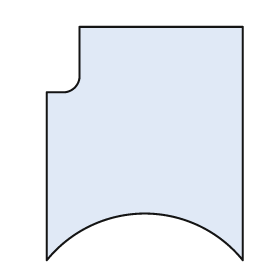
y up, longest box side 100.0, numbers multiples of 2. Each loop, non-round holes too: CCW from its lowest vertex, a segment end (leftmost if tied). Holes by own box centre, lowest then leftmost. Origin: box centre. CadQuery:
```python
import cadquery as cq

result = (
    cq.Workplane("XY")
    .moveTo(-42.0, -50.0)
    .threePointArc((0.0, -30.0), (42.0, -50.0))
    .lineTo(42.0, 50.0)
    .lineTo(-28.0, 50.0)
    .lineTo(-28.0, 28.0)
    .threePointArc((-30.0, 24.0), (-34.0, 22.0))
    .lineTo(-42.0, 22.0)
    .close()
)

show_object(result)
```